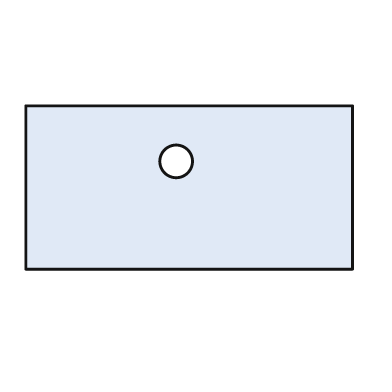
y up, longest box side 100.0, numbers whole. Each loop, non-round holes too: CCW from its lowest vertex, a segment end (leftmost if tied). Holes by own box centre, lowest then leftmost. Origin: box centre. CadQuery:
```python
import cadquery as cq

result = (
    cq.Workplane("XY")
    .moveTo(-50.0, -25.0)
    .lineTo(50.0, -25.0)
    .lineTo(50.0, 25.0)
    .lineTo(-50.0, 25.0)
    .close()
    .moveTo(-4.0, 8.0)
    .circle(5.0)
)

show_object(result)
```